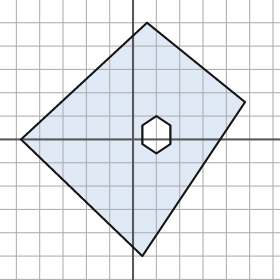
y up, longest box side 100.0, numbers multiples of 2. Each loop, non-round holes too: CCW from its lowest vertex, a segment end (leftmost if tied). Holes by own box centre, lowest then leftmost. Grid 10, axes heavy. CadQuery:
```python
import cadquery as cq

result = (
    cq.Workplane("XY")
    .moveTo(4.0, -50.0)
    .lineTo(48.0, 16.0)
    .lineTo(6.0, 50.0)
    .lineTo(-48.0, 0.0)
    .close()
    .moveTo(10.0, -6.0)
    .lineTo(16.0, -2.0)
    .lineTo(16.0, 6.0)
    .lineTo(10.0, 10.0)
    .lineTo(4.0, 6.0)
    .lineTo(4.0, -2.0)
    .close()
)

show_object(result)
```